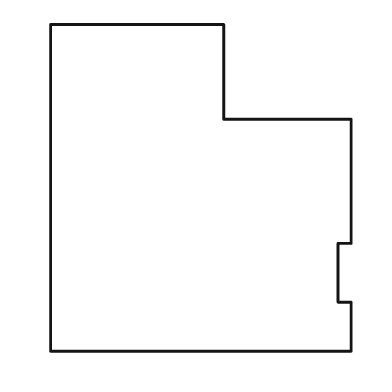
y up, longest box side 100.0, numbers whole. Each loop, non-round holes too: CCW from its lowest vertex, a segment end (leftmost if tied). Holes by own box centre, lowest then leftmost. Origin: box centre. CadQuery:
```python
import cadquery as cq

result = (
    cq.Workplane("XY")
    .moveTo(-46.0, -50.0)
    .lineTo(46.0, -50.0)
    .lineTo(46.0, -35.0)
    .lineTo(42.0, -35.0)
    .lineTo(42.0, -17.0)
    .lineTo(46.0, -17.0)
    .lineTo(46.0, 21.0)
    .lineTo(7.0, 21.0)
    .lineTo(7.0, 50.0)
    .lineTo(-46.0, 50.0)
    .close()
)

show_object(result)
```